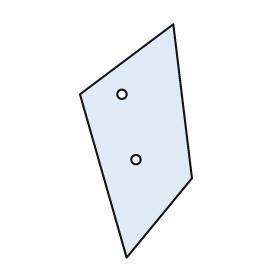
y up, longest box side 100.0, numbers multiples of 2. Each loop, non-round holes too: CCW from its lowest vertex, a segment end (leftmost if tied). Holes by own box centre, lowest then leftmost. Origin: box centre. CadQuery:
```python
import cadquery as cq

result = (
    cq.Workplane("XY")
    .moveTo(-4.0, -50.0)
    .lineTo(24.0, -16.0)
    .lineTo(16.0, 50.0)
    .lineTo(-24.0, 20.0)
    .close()
    .moveTo(0.0, -8.0)
    .circle(2.0)
    .moveTo(-6.0, 20.0)
    .circle(2.0)
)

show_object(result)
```